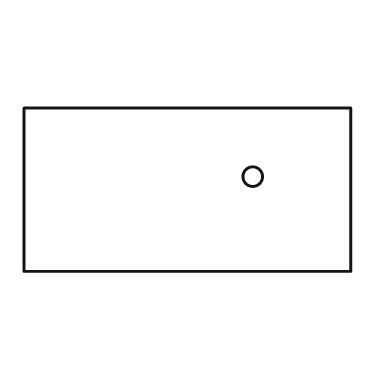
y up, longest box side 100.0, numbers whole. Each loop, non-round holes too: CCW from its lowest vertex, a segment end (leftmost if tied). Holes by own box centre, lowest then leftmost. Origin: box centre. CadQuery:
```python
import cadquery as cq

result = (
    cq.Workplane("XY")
    .moveTo(-50.0, -25.0)
    .lineTo(50.0, -25.0)
    .lineTo(50.0, 25.0)
    .lineTo(-50.0, 25.0)
    .close()
    .moveTo(20.0, 4.0)
    .circle(3.0)
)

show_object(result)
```